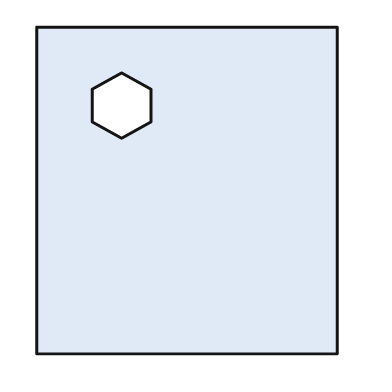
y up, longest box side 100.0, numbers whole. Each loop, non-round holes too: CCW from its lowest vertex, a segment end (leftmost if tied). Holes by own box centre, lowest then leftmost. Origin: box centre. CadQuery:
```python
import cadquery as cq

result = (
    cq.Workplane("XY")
    .moveTo(-46.0, -50.0)
    .lineTo(46.0, -50.0)
    .lineTo(46.0, 50.0)
    .lineTo(-46.0, 50.0)
    .close()
    .moveTo(-20.0, 16.0)
    .lineTo(-11.0, 21.0)
    .lineTo(-11.0, 31.0)
    .lineTo(-20.0, 36.0)
    .lineTo(-29.0, 31.0)
    .lineTo(-29.0, 21.0)
    .close()
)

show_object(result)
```